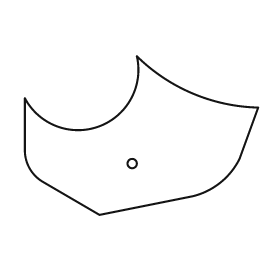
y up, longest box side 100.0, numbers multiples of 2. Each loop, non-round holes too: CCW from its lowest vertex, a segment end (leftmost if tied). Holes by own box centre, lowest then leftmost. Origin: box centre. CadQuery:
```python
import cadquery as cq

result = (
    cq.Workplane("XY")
    .moveTo(-18.0, -34.0)
    .lineTo(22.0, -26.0)
    .threePointArc((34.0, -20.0), (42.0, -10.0))
    .lineTo(50.0, 12.0)
    .threePointArc((22.0, 18.0), (-2.0, 34.0))
    .threePointArc((-18.0, 4.0), (-50.0, 16.0))
    .lineTo(-50.0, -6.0)
    .threePointArc((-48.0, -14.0), (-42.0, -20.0))
    .close()
    .moveTo(-4.0, -12.0)
    .circle(2.0)
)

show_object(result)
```